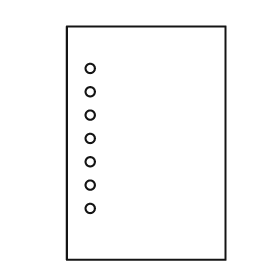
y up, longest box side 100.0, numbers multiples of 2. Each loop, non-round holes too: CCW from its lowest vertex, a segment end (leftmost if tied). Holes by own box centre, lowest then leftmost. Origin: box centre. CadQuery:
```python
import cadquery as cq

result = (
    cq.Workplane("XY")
    .moveTo(-34.0, -50.0)
    .lineTo(34.0, -50.0)
    .lineTo(34.0, 50.0)
    .lineTo(-34.0, 50.0)
    .close()
    .moveTo(-24.0, -28.0)
    .circle(2.0)
    .moveTo(-24.0, -18.0)
    .circle(2.0)
    .moveTo(-24.0, -8.0)
    .circle(2.0)
    .moveTo(-24.0, 2.0)
    .circle(2.0)
    .moveTo(-24.0, 12.0)
    .circle(2.0)
    .moveTo(-24.0, 22.0)
    .circle(2.0)
    .moveTo(-24.0, 32.0)
    .circle(2.0)
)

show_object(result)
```